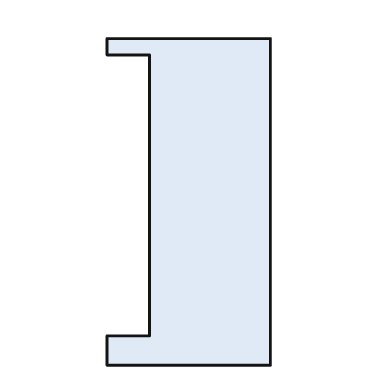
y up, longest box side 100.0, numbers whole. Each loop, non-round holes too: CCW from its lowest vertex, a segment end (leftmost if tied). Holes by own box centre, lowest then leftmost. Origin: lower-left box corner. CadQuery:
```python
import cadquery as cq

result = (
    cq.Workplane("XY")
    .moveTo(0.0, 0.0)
    .lineTo(50.0, 0.0)
    .lineTo(50.0, 100.0)
    .lineTo(0.0, 100.0)
    .lineTo(0.0, 95.0)
    .lineTo(13.0, 95.0)
    .lineTo(13.0, 9.0)
    .lineTo(0.0, 9.0)
    .close()
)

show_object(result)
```